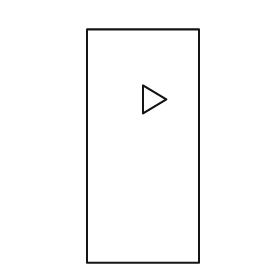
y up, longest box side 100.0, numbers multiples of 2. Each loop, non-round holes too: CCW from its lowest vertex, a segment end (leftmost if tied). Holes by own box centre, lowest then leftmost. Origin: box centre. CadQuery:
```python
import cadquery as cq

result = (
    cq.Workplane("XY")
    .moveTo(-24.0, -50.0)
    .lineTo(24.0, -50.0)
    .lineTo(24.0, 50.0)
    .lineTo(-24.0, 50.0)
    .close()
    .moveTo(0.0, 14.0)
    .lineTo(10.0, 20.0)
    .lineTo(0.0, 26.0)
    .close()
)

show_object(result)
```